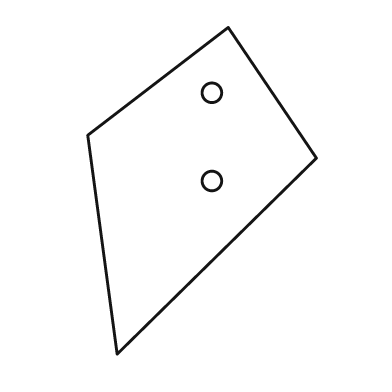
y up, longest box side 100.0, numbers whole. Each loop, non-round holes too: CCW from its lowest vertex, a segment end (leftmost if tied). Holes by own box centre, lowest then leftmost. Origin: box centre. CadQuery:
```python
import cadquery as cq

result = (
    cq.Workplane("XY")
    .moveTo(-26.0, -50.0)
    .lineTo(35.0, 10.0)
    .lineTo(8.0, 50.0)
    .lineTo(-35.0, 17.0)
    .close()
    .moveTo(3.0, 3.0)
    .circle(3.0)
    .moveTo(3.0, 30.0)
    .circle(3.0)
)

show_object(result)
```